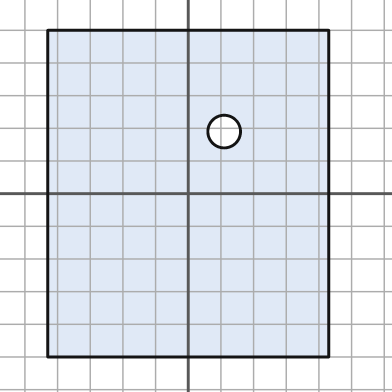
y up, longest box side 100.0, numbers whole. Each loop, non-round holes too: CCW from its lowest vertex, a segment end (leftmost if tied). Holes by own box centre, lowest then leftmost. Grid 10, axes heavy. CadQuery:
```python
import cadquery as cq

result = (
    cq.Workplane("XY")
    .moveTo(-43.0, -50.0)
    .lineTo(43.0, -50.0)
    .lineTo(43.0, 50.0)
    .lineTo(-43.0, 50.0)
    .close()
    .moveTo(11.0, 19.0)
    .circle(5.0)
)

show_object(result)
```